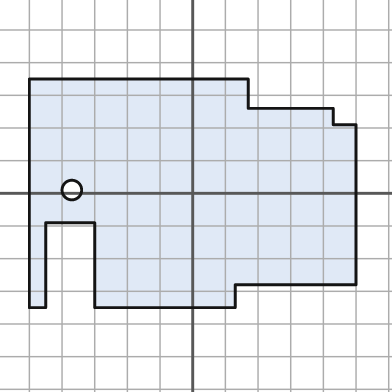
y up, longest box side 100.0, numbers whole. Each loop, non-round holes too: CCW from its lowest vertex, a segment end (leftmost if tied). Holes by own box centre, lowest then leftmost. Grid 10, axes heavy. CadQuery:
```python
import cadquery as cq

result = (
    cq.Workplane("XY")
    .moveTo(-50.0, -35.0)
    .lineTo(-45.0, -35.0)
    .lineTo(-45.0, -9.0)
    .lineTo(-30.0, -9.0)
    .lineTo(-30.0, -35.0)
    .lineTo(13.0, -35.0)
    .lineTo(13.0, -28.0)
    .lineTo(50.0, -28.0)
    .lineTo(50.0, 21.0)
    .lineTo(43.0, 21.0)
    .lineTo(43.0, 26.0)
    .lineTo(17.0, 26.0)
    .lineTo(17.0, 35.0)
    .lineTo(-50.0, 35.0)
    .close()
    .moveTo(-37.0, 1.0)
    .circle(3.0)
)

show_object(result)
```